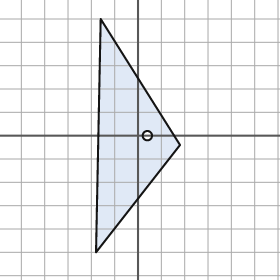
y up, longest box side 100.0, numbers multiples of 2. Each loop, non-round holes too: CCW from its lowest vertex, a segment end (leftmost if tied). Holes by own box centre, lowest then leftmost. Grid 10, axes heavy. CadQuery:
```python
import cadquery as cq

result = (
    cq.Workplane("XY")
    .moveTo(-18.0, -50.0)
    .lineTo(18.0, -4.0)
    .lineTo(-16.0, 50.0)
    .close()
    .moveTo(4.0, 0.0)
    .circle(2.0)
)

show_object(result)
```